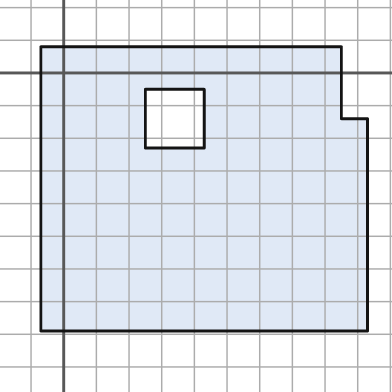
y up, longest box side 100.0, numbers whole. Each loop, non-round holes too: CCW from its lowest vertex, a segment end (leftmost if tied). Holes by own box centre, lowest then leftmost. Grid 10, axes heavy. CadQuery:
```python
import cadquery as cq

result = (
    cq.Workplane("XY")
    .moveTo(-7.0, -79.0)
    .lineTo(93.0, -79.0)
    .lineTo(93.0, -14.0)
    .lineTo(85.0, -14.0)
    .lineTo(85.0, 8.0)
    .lineTo(-7.0, 8.0)
    .close()
    .moveTo(25.0, -23.0)
    .lineTo(43.0, -23.0)
    .lineTo(43.0, -5.0)
    .lineTo(25.0, -5.0)
    .close()
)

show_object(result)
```